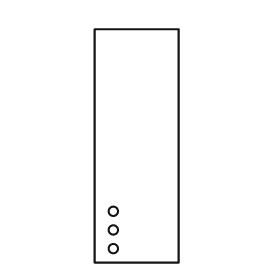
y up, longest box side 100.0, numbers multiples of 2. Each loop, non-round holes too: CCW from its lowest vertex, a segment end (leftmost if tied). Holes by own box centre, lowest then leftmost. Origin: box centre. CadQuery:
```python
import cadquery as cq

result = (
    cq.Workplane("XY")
    .moveTo(-18.0, -50.0)
    .lineTo(18.0, -50.0)
    .lineTo(18.0, 50.0)
    .lineTo(-18.0, 50.0)
    .close()
    .moveTo(-10.0, -44.0)
    .circle(2.0)
    .moveTo(-10.0, -36.0)
    .circle(2.0)
    .moveTo(-10.0, -28.0)
    .circle(2.0)
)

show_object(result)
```